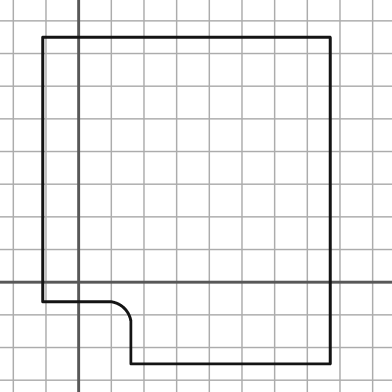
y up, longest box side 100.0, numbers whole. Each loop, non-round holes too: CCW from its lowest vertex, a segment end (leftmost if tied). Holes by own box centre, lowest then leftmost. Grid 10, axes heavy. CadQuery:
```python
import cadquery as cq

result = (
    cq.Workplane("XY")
    .moveTo(16.0, -25.0)
    .lineTo(77.0, -25.0)
    .lineTo(77.0, 75.0)
    .lineTo(-11.0, 75.0)
    .lineTo(-11.0, -6.0)
    .lineTo(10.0, -6.0)
    .threePointArc((14.0, -8.0), (16.0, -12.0))
    .close()
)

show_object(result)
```